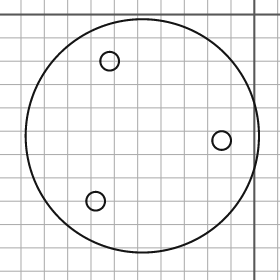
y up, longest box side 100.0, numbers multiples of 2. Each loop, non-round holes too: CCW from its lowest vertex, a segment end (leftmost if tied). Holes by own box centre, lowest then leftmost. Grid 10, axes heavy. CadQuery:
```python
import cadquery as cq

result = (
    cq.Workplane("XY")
    .moveTo(-48.0, -52.0)
    .circle(50.0)
    .moveTo(-68.0, -80.0)
    .circle(4.0)
    .moveTo(-14.0, -54.0)
    .circle(4.0)
    .moveTo(-62.0, -20.0)
    .circle(4.0)
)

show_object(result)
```